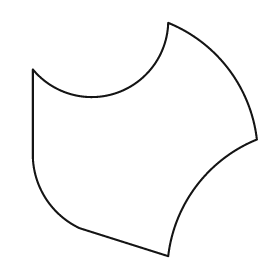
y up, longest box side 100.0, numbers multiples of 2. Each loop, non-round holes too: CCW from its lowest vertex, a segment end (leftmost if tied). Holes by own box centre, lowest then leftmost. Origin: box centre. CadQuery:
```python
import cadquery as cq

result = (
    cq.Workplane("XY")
    .moveTo(10.0, -50.0)
    .threePointArc((22.0, -20.0), (48.0, 0.0))
    .threePointArc((36.0, 30.0), (10.0, 50.0))
    .threePointArc((-12.0, 20.0), (-48.0, 30.0))
    .lineTo(-48.0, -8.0)
    .threePointArc((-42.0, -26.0), (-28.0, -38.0))
    .close()
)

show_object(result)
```